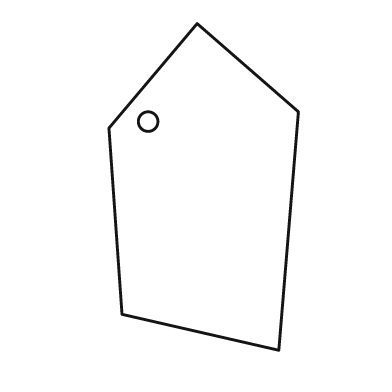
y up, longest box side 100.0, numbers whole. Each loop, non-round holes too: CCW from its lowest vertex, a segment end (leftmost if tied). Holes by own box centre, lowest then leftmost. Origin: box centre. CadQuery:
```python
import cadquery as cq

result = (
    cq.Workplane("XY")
    .moveTo(23.0, -50.0)
    .lineTo(29.0, 23.0)
    .lineTo(-2.0, 50.0)
    .lineTo(-29.0, 18.0)
    .lineTo(-25.0, -39.0)
    .close()
    .moveTo(-17.0, 20.0)
    .circle(3.0)
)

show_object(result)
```